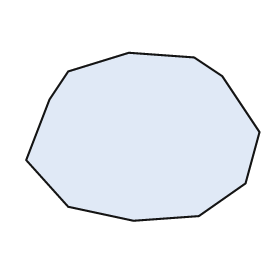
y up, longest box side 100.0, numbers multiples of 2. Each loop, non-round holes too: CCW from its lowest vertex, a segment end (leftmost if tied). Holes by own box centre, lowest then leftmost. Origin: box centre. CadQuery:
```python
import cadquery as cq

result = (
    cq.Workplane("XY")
    .moveTo(-4.0, -36.0)
    .lineTo(24.0, -34.0)
    .lineTo(44.0, -20.0)
    .lineTo(50.0, 2.0)
    .lineTo(34.0, 26.0)
    .lineTo(22.0, 34.0)
    .lineTo(-6.0, 36.0)
    .lineTo(-32.0, 28.0)
    .lineTo(-40.0, 16.0)
    .lineTo(-50.0, -10.0)
    .lineTo(-32.0, -30.0)
    .close()
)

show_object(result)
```